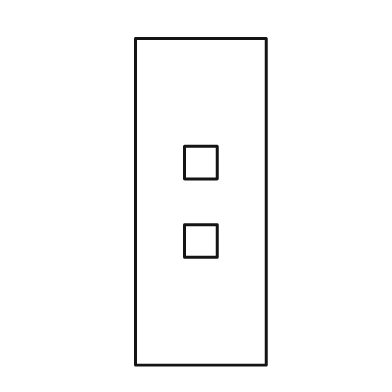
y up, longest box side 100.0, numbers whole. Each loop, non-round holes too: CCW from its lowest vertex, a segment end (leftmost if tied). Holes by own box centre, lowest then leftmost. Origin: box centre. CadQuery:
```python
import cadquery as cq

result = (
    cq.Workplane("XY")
    .moveTo(-20.0, -50.0)
    .lineTo(20.0, -50.0)
    .lineTo(20.0, 50.0)
    .lineTo(-20.0, 50.0)
    .close()
    .moveTo(-5.0, -17.0)
    .lineTo(5.0, -17.0)
    .lineTo(5.0, -7.0)
    .lineTo(-5.0, -7.0)
    .close()
    .moveTo(-5.0, 7.0)
    .lineTo(5.0, 7.0)
    .lineTo(5.0, 17.0)
    .lineTo(-5.0, 17.0)
    .close()
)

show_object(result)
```